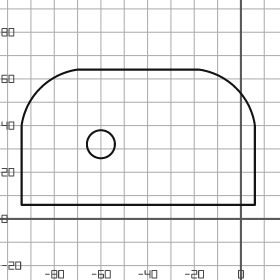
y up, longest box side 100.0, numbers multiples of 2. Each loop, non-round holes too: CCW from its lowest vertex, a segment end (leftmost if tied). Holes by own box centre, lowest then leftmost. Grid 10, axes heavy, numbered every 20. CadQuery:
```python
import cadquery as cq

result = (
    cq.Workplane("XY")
    .moveTo(-94.0, 6.0)
    .lineTo(6.0, 6.0)
    .lineTo(6.0, 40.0)
    .threePointArc((-2.0, 56.0), (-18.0, 64.0))
    .lineTo(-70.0, 64.0)
    .threePointArc((-86.0, 56.0), (-94.0, 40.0))
    .close()
    .moveTo(-60.0, 32.0)
    .circle(6.0)
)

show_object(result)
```